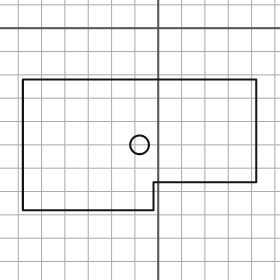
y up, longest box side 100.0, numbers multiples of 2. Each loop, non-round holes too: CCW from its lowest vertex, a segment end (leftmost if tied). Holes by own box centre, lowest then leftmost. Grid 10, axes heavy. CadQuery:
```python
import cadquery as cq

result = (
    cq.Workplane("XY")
    .moveTo(-58.0, -78.0)
    .lineTo(-2.0, -78.0)
    .lineTo(-2.0, -66.0)
    .lineTo(42.0, -66.0)
    .lineTo(42.0, -22.0)
    .lineTo(-58.0, -22.0)
    .close()
    .moveTo(-8.0, -50.0)
    .circle(4.0)
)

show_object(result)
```